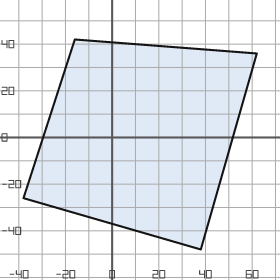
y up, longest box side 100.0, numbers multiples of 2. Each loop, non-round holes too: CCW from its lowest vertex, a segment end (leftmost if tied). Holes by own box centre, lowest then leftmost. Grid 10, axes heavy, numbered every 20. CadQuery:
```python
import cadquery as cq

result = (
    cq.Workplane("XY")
    .moveTo(38.0, -48.0)
    .lineTo(62.0, 36.0)
    .lineTo(-16.0, 42.0)
    .lineTo(-38.0, -26.0)
    .close()
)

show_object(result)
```